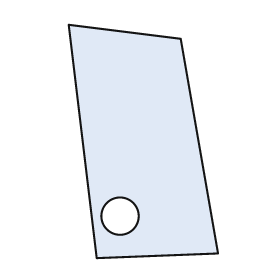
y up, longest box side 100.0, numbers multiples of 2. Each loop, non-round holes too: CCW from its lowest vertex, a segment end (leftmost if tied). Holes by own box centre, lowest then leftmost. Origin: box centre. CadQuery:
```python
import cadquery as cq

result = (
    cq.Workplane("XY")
    .moveTo(-20.0, -50.0)
    .lineTo(32.0, -48.0)
    .lineTo(16.0, 44.0)
    .lineTo(-32.0, 50.0)
    .close()
    .moveTo(-10.0, -32.0)
    .circle(8.0)
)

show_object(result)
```